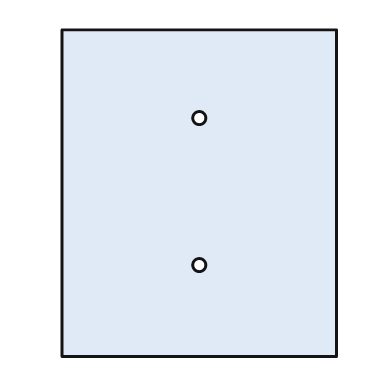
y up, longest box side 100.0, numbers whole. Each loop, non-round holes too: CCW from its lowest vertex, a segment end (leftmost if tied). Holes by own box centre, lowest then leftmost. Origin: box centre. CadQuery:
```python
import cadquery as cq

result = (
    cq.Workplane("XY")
    .moveTo(-42.0, -50.0)
    .lineTo(42.0, -50.0)
    .lineTo(42.0, 50.0)
    .lineTo(-42.0, 50.0)
    .close()
    .moveTo(0.0, -22.0)
    .circle(2.0)
    .moveTo(0.0, 23.0)
    .circle(2.0)
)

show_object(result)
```